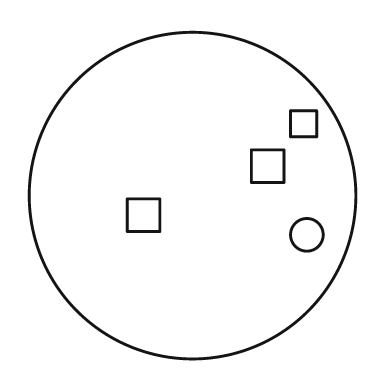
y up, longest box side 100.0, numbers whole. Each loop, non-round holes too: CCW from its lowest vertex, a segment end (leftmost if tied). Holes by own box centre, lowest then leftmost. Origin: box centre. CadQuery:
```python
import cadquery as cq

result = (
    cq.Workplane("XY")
    .moveTo(0.0, 0.0)
    .circle(50.0)
    .moveTo(35.0, -12.0)
    .circle(5.0)
    .moveTo(-20.0, -11.0)
    .lineTo(-10.0, -11.0)
    .lineTo(-10.0, -1.0)
    .lineTo(-20.0, -1.0)
    .close()
    .moveTo(18.0, 4.0)
    .lineTo(28.0, 4.0)
    .lineTo(28.0, 14.0)
    .lineTo(18.0, 14.0)
    .close()
    .moveTo(30.0, 18.0)
    .lineTo(38.0, 18.0)
    .lineTo(38.0, 26.0)
    .lineTo(30.0, 26.0)
    .close()
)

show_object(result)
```